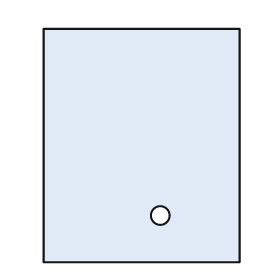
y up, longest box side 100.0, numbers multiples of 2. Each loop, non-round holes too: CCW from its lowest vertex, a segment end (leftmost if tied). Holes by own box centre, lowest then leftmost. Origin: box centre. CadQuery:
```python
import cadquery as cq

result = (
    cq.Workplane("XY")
    .moveTo(-42.0, -50.0)
    .lineTo(42.0, -50.0)
    .lineTo(42.0, 50.0)
    .lineTo(-42.0, 50.0)
    .close()
    .moveTo(8.0, -30.0)
    .circle(4.0)
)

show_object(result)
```